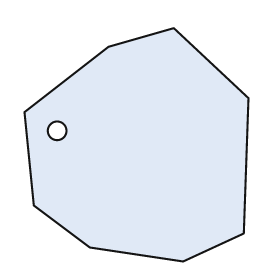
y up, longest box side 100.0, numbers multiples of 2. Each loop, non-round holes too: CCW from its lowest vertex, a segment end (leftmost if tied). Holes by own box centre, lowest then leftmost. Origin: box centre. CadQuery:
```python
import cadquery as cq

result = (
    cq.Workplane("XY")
    .moveTo(20.0, -50.0)
    .lineTo(46.0, -38.0)
    .lineTo(48.0, 20.0)
    .lineTo(16.0, 50.0)
    .lineTo(-12.0, 42.0)
    .lineTo(-48.0, 14.0)
    .lineTo(-44.0, -26.0)
    .lineTo(-20.0, -44.0)
    .close()
    .moveTo(-34.0, 6.0)
    .circle(4.0)
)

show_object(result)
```